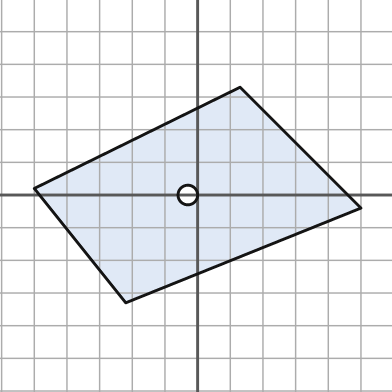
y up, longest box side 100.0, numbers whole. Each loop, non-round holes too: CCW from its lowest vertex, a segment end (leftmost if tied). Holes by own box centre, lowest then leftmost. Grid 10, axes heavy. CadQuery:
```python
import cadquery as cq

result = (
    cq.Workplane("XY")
    .moveTo(-22.0, -33.0)
    .lineTo(50.0, -4.0)
    .lineTo(13.0, 33.0)
    .lineTo(-50.0, 2.0)
    .close()
    .moveTo(-3.0, 0.0)
    .circle(3.0)
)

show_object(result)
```